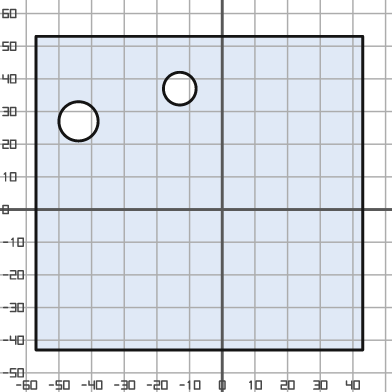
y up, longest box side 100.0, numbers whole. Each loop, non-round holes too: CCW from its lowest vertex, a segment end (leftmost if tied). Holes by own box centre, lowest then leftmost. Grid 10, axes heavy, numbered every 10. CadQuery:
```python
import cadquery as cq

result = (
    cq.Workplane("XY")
    .moveTo(-57.0, -43.0)
    .lineTo(43.0, -43.0)
    .lineTo(43.0, 53.0)
    .lineTo(-57.0, 53.0)
    .close()
    .moveTo(-44.0, 27.0)
    .circle(6.0)
    .moveTo(-13.0, 37.0)
    .circle(5.0)
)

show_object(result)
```